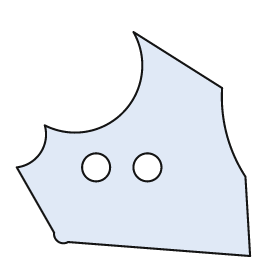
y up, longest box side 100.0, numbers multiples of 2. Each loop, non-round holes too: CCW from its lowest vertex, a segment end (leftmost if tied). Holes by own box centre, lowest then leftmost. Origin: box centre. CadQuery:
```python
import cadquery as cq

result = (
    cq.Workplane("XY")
    .moveTo(50.0, -48.0)
    .lineTo(48.0, -14.0)
    .threePointArc((40.0, 4.0), (38.0, 24.0))
    .lineTo(0.0, 48.0)
    .threePointArc((-4.0, 14.0), (-38.0, 8.0))
    .threePointArc((-40.0, -4.0), (-50.0, -10.0))
    .lineTo(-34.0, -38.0)
    .threePointArc((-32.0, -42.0), (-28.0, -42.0))
    .close()
    .moveTo(-16.0, -10.0)
    .circle(6.0)
    .moveTo(6.0, -10.0)
    .circle(6.0)
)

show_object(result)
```